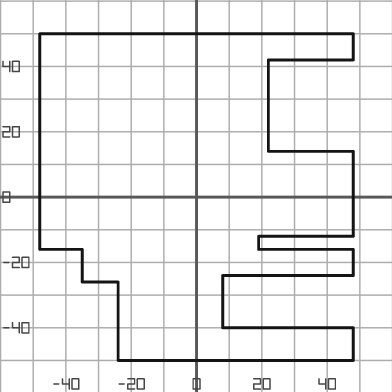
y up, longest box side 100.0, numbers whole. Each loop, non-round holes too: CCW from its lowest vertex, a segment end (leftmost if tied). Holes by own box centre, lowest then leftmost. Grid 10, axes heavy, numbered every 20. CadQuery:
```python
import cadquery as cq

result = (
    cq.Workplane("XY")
    .moveTo(-24.0, -50.0)
    .lineTo(48.0, -50.0)
    .lineTo(48.0, -40.0)
    .lineTo(8.0, -40.0)
    .lineTo(8.0, -24.0)
    .lineTo(48.0, -24.0)
    .lineTo(48.0, -16.0)
    .lineTo(19.0, -16.0)
    .lineTo(19.0, -12.0)
    .lineTo(48.0, -12.0)
    .lineTo(48.0, 14.0)
    .lineTo(22.0, 14.0)
    .lineTo(22.0, 42.0)
    .lineTo(48.0, 42.0)
    .lineTo(48.0, 50.0)
    .lineTo(-48.0, 50.0)
    .lineTo(-48.0, -16.0)
    .lineTo(-35.0, -16.0)
    .lineTo(-35.0, -26.0)
    .lineTo(-24.0, -26.0)
    .close()
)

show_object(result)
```